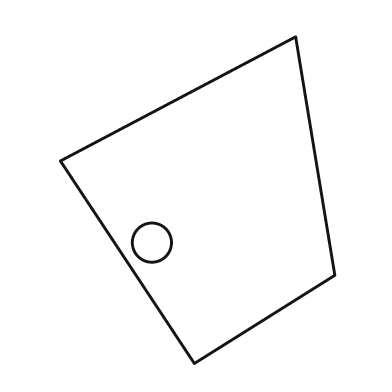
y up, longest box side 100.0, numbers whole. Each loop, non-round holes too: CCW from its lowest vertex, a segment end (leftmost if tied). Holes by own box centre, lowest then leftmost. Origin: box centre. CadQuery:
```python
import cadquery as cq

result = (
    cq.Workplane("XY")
    .moveTo(-1.0, -50.0)
    .lineTo(42.0, -23.0)
    .lineTo(30.0, 50.0)
    .lineTo(-42.0, 12.0)
    .close()
    .moveTo(-14.0, -13.0)
    .circle(6.0)
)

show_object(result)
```